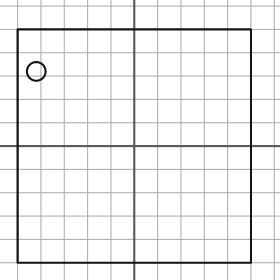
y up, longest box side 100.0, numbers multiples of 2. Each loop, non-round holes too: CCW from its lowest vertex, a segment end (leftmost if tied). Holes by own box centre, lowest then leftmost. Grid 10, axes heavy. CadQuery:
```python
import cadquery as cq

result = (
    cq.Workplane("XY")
    .moveTo(-50.0, -50.0)
    .lineTo(50.0, -50.0)
    .lineTo(50.0, 50.0)
    .lineTo(-50.0, 50.0)
    .close()
    .moveTo(-42.0, 32.0)
    .circle(4.0)
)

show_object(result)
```